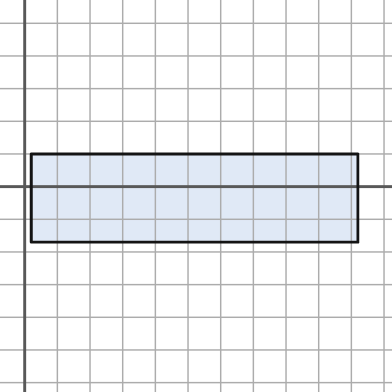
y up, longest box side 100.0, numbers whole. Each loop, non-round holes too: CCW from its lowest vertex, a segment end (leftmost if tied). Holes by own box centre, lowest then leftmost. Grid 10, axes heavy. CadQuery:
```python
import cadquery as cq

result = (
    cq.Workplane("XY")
    .moveTo(2.0, -17.0)
    .lineTo(102.0, -17.0)
    .lineTo(102.0, 10.0)
    .lineTo(2.0, 10.0)
    .close()
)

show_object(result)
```